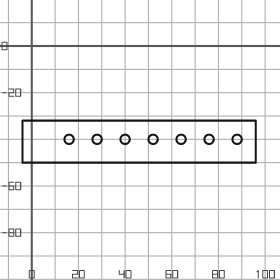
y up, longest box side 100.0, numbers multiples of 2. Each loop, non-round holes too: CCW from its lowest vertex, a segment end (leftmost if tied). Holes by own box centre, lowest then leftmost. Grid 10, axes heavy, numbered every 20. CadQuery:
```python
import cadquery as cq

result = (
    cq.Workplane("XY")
    .moveTo(-4.0, -50.0)
    .lineTo(96.0, -50.0)
    .lineTo(96.0, -32.0)
    .lineTo(-4.0, -32.0)
    .close()
    .moveTo(16.0, -40.0)
    .circle(2.0)
    .moveTo(28.0, -40.0)
    .circle(2.0)
    .moveTo(40.0, -40.0)
    .circle(2.0)
    .moveTo(52.0, -40.0)
    .circle(2.0)
    .moveTo(64.0, -40.0)
    .circle(2.0)
    .moveTo(76.0, -40.0)
    .circle(2.0)
    .moveTo(88.0, -40.0)
    .circle(2.0)
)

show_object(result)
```